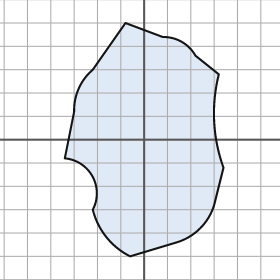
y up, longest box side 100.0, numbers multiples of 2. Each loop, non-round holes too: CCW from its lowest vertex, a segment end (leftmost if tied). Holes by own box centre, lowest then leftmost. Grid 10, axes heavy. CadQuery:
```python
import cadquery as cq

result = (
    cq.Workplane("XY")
    .moveTo(-6.0, -50.0)
    .lineTo(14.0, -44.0)
    .threePointArc((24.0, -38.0), (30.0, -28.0))
    .lineTo(34.0, -12.0)
    .threePointArc((30.0, 8.0), (32.0, 28.0))
    .lineTo(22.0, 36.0)
    .threePointArc((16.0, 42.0), (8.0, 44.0))
    .lineTo(-8.0, 50.0)
    .lineTo(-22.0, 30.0)
    .threePointArc((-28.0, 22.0), (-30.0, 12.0))
    .lineTo(-34.0, -8.0)
    .threePointArc((-22.0, -16.0), (-22.0, -30.0))
    .threePointArc((-16.0, -42.0), (-6.0, -50.0))
    .close()
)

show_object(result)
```